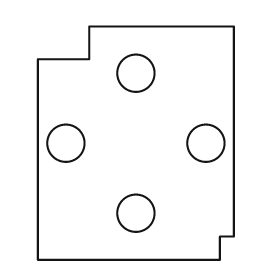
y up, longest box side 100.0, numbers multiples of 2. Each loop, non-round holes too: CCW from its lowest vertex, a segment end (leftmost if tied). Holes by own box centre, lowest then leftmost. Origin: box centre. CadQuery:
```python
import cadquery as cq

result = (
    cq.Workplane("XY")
    .moveTo(-42.0, -50.0)
    .lineTo(36.0, -50.0)
    .lineTo(36.0, -40.0)
    .lineTo(42.0, -40.0)
    .lineTo(42.0, 50.0)
    .lineTo(-20.0, 50.0)
    .lineTo(-20.0, 36.0)
    .lineTo(-42.0, 36.0)
    .close()
    .moveTo(0.0, -30.0)
    .circle(8.0)
    .moveTo(-30.0, 0.0)
    .circle(8.0)
    .moveTo(30.0, 0.0)
    .circle(8.0)
    .moveTo(0.0, 30.0)
    .circle(8.0)
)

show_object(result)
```